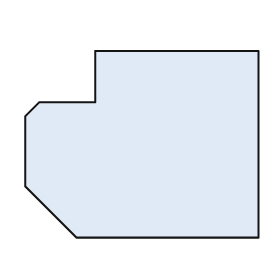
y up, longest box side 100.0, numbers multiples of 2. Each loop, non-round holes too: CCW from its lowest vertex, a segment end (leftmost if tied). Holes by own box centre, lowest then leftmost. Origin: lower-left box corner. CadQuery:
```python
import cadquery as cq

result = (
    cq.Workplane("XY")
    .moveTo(22.0, 0.0)
    .lineTo(100.0, 0.0)
    .lineTo(100.0, 80.0)
    .lineTo(30.0, 80.0)
    .lineTo(30.0, 58.0)
    .lineTo(6.0, 58.0)
    .lineTo(0.0, 52.0)
    .lineTo(0.0, 22.0)
    .close()
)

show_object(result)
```